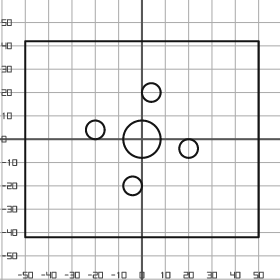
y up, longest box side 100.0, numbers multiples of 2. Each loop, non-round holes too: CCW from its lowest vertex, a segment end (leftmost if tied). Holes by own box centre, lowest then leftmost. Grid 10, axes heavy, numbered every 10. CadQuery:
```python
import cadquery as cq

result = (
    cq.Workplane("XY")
    .moveTo(-50.0, -42.0)
    .lineTo(50.0, -42.0)
    .lineTo(50.0, 42.0)
    .lineTo(-50.0, 42.0)
    .close()
    .moveTo(-4.0, -20.0)
    .circle(4.0)
    .moveTo(20.0, -4.0)
    .circle(4.0)
    .moveTo(0.0, 0.0)
    .circle(8.0)
    .moveTo(-20.0, 4.0)
    .circle(4.0)
    .moveTo(4.0, 20.0)
    .circle(4.0)
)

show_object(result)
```